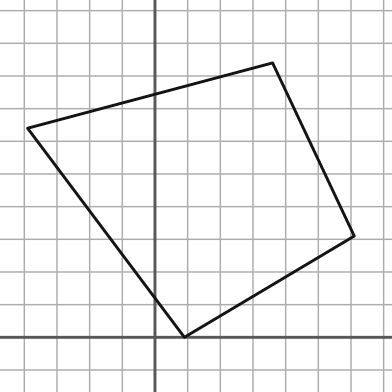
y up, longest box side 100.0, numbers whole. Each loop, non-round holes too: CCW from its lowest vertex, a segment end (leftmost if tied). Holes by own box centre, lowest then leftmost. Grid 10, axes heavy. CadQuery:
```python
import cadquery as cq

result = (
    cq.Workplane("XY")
    .moveTo(9.0, 0.0)
    .lineTo(61.0, 31.0)
    .lineTo(36.0, 84.0)
    .lineTo(-39.0, 64.0)
    .close()
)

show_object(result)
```